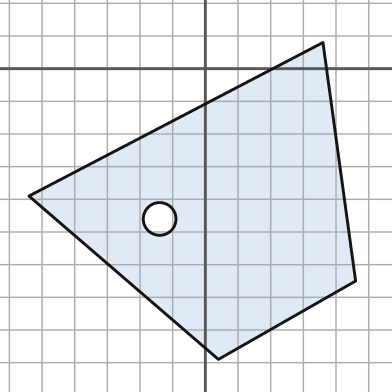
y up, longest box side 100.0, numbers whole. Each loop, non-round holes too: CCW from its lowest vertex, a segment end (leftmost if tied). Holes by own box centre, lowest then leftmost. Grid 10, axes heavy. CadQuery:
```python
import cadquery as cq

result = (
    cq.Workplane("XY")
    .moveTo(4.0, -89.0)
    .lineTo(46.0, -65.0)
    .lineTo(36.0, 8.0)
    .lineTo(-54.0, -39.0)
    .close()
    .moveTo(-14.0, -46.0)
    .circle(5.0)
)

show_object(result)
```